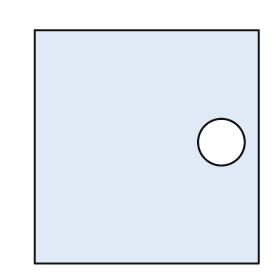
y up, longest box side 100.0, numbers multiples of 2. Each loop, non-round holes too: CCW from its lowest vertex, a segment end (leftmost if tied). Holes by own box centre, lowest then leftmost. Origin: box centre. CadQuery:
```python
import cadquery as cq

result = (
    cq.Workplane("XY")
    .moveTo(-48.0, -50.0)
    .lineTo(48.0, -50.0)
    .lineTo(48.0, 50.0)
    .lineTo(-48.0, 50.0)
    .close()
    .moveTo(32.0, 2.0)
    .circle(10.0)
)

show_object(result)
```